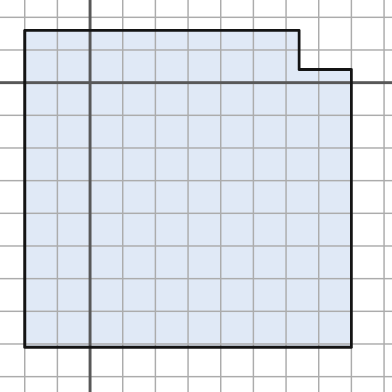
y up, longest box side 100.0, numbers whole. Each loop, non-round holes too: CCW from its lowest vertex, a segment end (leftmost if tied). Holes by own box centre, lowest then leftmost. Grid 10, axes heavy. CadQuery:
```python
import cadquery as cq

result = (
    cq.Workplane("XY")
    .moveTo(-20.0, -81.0)
    .lineTo(80.0, -81.0)
    .lineTo(80.0, 4.0)
    .lineTo(64.0, 4.0)
    .lineTo(64.0, 16.0)
    .lineTo(-20.0, 16.0)
    .close()
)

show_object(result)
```